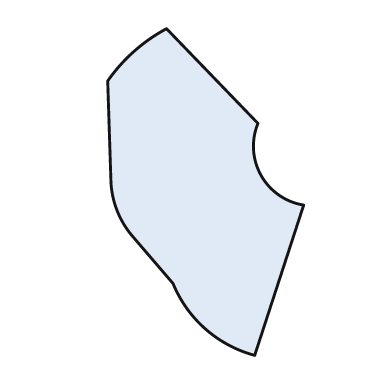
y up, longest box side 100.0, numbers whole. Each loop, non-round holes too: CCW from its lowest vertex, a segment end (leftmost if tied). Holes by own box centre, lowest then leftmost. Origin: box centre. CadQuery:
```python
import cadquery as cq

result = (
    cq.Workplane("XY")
    .moveTo(15.0, -50.0)
    .lineTo(30.0, -4.0)
    .threePointArc((17.0, 5.0), (16.0, 21.0))
    .lineTo(-12.0, 50.0)
    .threePointArc((-22.0, 43.0), (-30.0, 34.0))
    .lineTo(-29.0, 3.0)
    .threePointArc((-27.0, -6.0), (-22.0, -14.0))
    .lineTo(-10.0, -28.0)
    .threePointArc((0.0, -42.0), (15.0, -50.0))
    .close()
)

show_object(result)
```